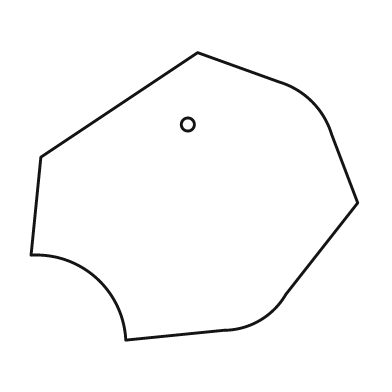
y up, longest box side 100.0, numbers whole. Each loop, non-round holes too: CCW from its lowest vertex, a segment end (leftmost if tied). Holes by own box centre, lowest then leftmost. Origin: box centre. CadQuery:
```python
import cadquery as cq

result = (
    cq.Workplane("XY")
    .moveTo(-21.0, -44.0)
    .lineTo(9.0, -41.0)
    .threePointArc((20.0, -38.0), (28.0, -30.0))
    .lineTo(50.0, -2.0)
    .lineTo(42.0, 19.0)
    .threePointArc((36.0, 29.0), (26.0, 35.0))
    .lineTo(1.0, 44.0)
    .lineTo(-47.0, 12.0)
    .lineTo(-50.0, -18.0)
    .threePointArc((-30.0, -25.0), (-21.0, -44.0))
    .close()
    .moveTo(-2.0, 22.0)
    .circle(2.0)
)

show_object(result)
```